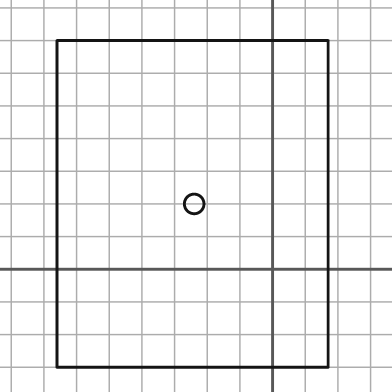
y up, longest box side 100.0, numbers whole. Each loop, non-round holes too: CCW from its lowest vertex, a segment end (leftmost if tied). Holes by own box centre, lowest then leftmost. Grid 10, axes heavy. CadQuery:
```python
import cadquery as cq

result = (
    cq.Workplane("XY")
    .moveTo(-66.0, -30.0)
    .lineTo(17.0, -30.0)
    .lineTo(17.0, 70.0)
    .lineTo(-66.0, 70.0)
    .close()
    .moveTo(-24.0, 20.0)
    .circle(3.0)
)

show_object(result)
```